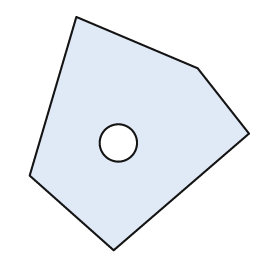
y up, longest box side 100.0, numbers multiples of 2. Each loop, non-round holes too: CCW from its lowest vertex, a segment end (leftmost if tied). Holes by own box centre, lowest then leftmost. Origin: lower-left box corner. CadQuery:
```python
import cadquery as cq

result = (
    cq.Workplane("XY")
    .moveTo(36.0, 0.0)
    .lineTo(94.0, 50.0)
    .lineTo(72.0, 78.0)
    .lineTo(20.0, 100.0)
    .lineTo(0.0, 32.0)
    .close()
    .moveTo(38.0, 46.0)
    .circle(8.0)
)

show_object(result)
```